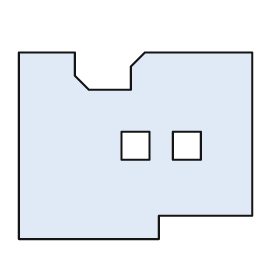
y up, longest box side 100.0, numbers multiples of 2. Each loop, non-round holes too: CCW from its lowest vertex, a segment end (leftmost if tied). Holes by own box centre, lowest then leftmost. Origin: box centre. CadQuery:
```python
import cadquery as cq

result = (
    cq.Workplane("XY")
    .moveTo(-50.0, -40.0)
    .lineTo(10.0, -40.0)
    .lineTo(10.0, -30.0)
    .lineTo(50.0, -30.0)
    .lineTo(50.0, 40.0)
    .lineTo(4.0, 40.0)
    .lineTo(-2.0, 34.0)
    .lineTo(-2.0, 24.0)
    .lineTo(-20.0, 24.0)
    .lineTo(-26.0, 30.0)
    .lineTo(-26.0, 40.0)
    .lineTo(-50.0, 40.0)
    .close()
    .moveTo(-6.0, -6.0)
    .lineTo(6.0, -6.0)
    .lineTo(6.0, 6.0)
    .lineTo(-6.0, 6.0)
    .close()
    .moveTo(16.0, -6.0)
    .lineTo(28.0, -6.0)
    .lineTo(28.0, 6.0)
    .lineTo(16.0, 6.0)
    .close()
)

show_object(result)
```